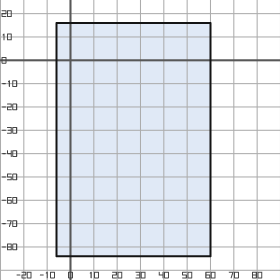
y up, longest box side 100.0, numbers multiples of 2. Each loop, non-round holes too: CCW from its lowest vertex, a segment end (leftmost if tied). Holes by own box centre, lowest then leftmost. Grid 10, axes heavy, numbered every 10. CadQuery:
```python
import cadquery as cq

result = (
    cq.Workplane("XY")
    .moveTo(-6.0, -84.0)
    .lineTo(60.0, -84.0)
    .lineTo(60.0, 16.0)
    .lineTo(-6.0, 16.0)
    .close()
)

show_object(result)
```